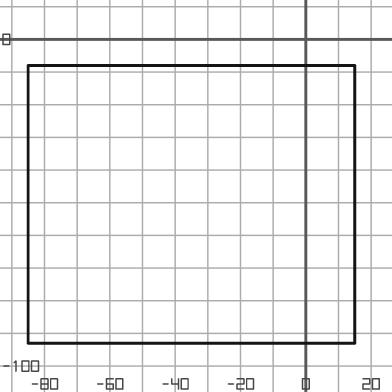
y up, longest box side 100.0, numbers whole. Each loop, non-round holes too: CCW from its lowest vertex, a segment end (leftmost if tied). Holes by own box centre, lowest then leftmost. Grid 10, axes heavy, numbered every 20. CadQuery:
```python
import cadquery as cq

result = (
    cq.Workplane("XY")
    .moveTo(-85.0, -93.0)
    .lineTo(15.0, -93.0)
    .lineTo(15.0, -8.0)
    .lineTo(-85.0, -8.0)
    .close()
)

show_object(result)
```